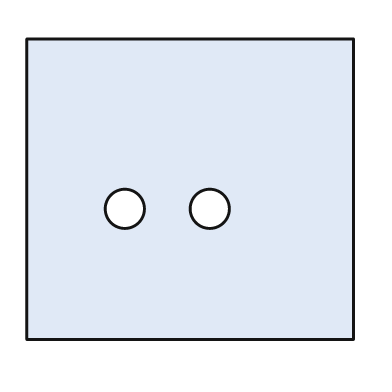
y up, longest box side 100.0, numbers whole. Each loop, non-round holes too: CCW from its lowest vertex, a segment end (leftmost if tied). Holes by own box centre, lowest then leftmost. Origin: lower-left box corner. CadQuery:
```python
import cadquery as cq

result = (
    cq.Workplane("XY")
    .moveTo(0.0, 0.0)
    .lineTo(100.0, 0.0)
    .lineTo(100.0, 92.0)
    .lineTo(0.0, 92.0)
    .close()
    .moveTo(30.0, 40.0)
    .circle(6.0)
    .moveTo(56.0, 40.0)
    .circle(6.0)
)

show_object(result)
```